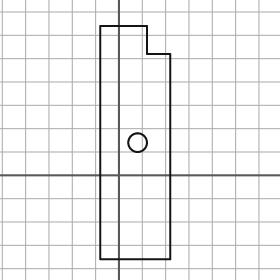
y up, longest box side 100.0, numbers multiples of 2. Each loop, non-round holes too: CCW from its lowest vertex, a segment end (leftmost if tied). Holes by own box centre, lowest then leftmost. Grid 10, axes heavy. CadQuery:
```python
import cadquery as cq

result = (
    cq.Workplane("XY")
    .moveTo(-8.0, -36.0)
    .lineTo(22.0, -36.0)
    .lineTo(22.0, 52.0)
    .lineTo(12.0, 52.0)
    .lineTo(12.0, 64.0)
    .lineTo(-8.0, 64.0)
    .close()
    .moveTo(8.0, 14.0)
    .circle(4.0)
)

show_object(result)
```